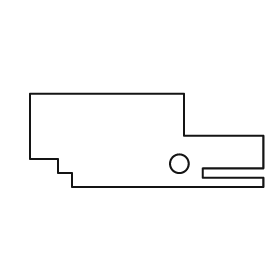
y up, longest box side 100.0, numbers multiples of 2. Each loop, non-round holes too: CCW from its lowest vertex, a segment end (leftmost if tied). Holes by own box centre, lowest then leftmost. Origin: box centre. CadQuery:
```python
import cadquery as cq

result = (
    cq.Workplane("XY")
    .moveTo(-32.0, -20.0)
    .lineTo(50.0, -20.0)
    .lineTo(50.0, -16.0)
    .lineTo(24.0, -16.0)
    .lineTo(24.0, -12.0)
    .lineTo(50.0, -12.0)
    .lineTo(50.0, 2.0)
    .lineTo(16.0, 2.0)
    .lineTo(16.0, 20.0)
    .lineTo(-50.0, 20.0)
    .lineTo(-50.0, -8.0)
    .lineTo(-38.0, -8.0)
    .lineTo(-38.0, -14.0)
    .lineTo(-32.0, -14.0)
    .close()
    .moveTo(14.0, -10.0)
    .circle(4.0)
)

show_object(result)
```